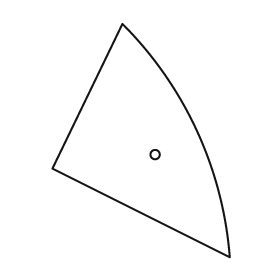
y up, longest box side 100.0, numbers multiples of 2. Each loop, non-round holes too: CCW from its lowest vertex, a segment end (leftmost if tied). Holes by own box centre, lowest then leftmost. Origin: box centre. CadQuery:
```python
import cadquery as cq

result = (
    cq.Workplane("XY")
    .moveTo(38.0, -50.0)
    .threePointArc((24.0, 4.0), (-8.0, 50.0))
    .lineTo(-38.0, -12.0)
    .close()
    .moveTo(6.0, -6.0)
    .circle(2.0)
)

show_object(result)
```